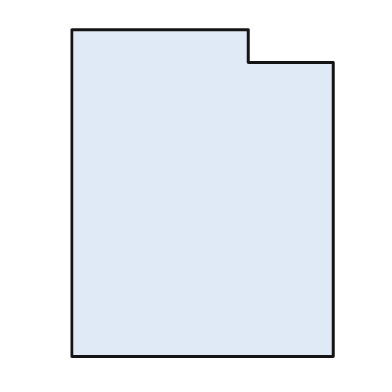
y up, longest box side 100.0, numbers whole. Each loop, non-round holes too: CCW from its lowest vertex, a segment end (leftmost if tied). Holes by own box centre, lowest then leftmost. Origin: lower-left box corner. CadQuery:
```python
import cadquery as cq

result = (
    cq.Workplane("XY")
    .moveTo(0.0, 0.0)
    .lineTo(80.0, 0.0)
    .lineTo(80.0, 90.0)
    .lineTo(54.0, 90.0)
    .lineTo(54.0, 100.0)
    .lineTo(0.0, 100.0)
    .close()
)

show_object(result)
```